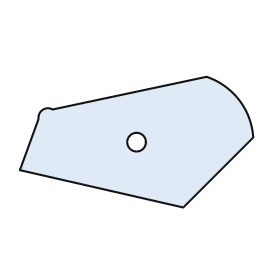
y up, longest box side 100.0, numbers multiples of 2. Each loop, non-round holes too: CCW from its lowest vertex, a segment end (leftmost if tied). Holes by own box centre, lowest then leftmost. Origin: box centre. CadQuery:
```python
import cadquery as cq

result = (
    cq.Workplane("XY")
    .moveTo(20.0, -28.0)
    .lineTo(50.0, 2.0)
    .threePointArc((44.0, 18.0), (30.0, 28.0))
    .lineTo(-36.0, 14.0)
    .threePointArc((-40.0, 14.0), (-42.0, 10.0))
    .lineTo(-50.0, -12.0)
    .close()
    .moveTo(0.0, 0.0)
    .circle(4.0)
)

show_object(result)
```